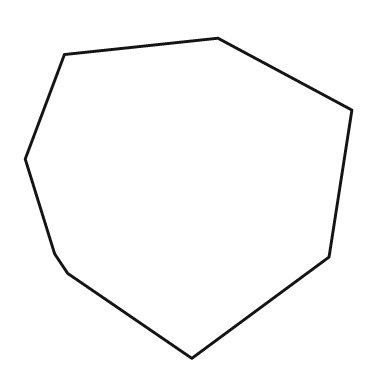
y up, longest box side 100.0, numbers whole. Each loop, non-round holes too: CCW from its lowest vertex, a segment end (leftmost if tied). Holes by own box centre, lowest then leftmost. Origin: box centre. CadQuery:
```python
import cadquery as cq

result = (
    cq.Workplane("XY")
    .moveTo(1.0, -49.0)
    .lineTo(43.0, -18.0)
    .lineTo(50.0, 27.0)
    .lineTo(9.0, 49.0)
    .lineTo(-38.0, 44.0)
    .lineTo(-50.0, 12.0)
    .lineTo(-41.0, -17.0)
    .lineTo(-37.0, -23.0)
    .close()
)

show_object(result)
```